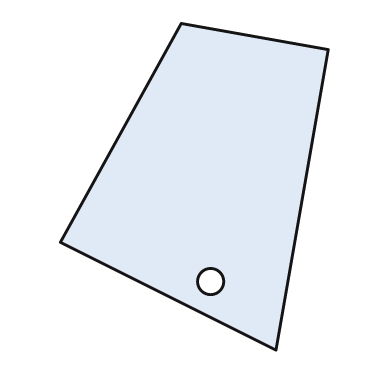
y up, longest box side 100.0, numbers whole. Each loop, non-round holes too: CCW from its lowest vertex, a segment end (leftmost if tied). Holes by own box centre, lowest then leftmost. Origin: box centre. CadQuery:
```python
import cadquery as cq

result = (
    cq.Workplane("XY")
    .moveTo(25.0, -50.0)
    .lineTo(41.0, 42.0)
    .lineTo(-4.0, 50.0)
    .lineTo(-41.0, -17.0)
    .close()
    .moveTo(5.0, -29.0)
    .circle(4.0)
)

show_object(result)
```